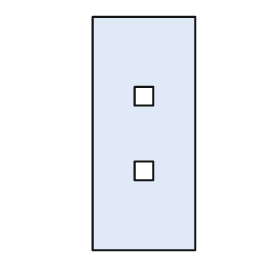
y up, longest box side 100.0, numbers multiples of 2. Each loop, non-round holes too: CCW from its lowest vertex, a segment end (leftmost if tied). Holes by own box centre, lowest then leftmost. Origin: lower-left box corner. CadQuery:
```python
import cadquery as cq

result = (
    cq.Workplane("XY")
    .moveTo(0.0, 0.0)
    .lineTo(44.0, 0.0)
    .lineTo(44.0, 100.0)
    .lineTo(0.0, 100.0)
    .close()
    .moveTo(18.0, 30.0)
    .lineTo(26.0, 30.0)
    .lineTo(26.0, 38.0)
    .lineTo(18.0, 38.0)
    .close()
    .moveTo(18.0, 62.0)
    .lineTo(26.0, 62.0)
    .lineTo(26.0, 70.0)
    .lineTo(18.0, 70.0)
    .close()
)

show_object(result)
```